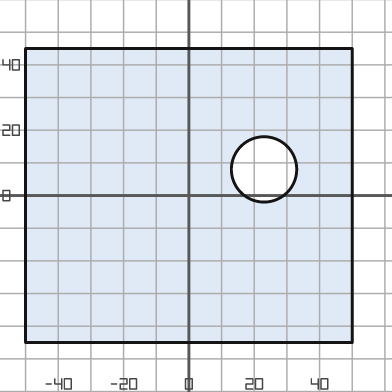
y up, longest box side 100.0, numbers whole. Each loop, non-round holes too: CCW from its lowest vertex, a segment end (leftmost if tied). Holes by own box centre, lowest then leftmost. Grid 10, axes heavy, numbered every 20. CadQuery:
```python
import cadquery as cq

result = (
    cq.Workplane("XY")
    .moveTo(-50.0, -45.0)
    .lineTo(50.0, -45.0)
    .lineTo(50.0, 45.0)
    .lineTo(-50.0, 45.0)
    .close()
    .moveTo(23.0, 8.0)
    .circle(10.0)
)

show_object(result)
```